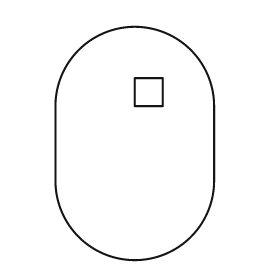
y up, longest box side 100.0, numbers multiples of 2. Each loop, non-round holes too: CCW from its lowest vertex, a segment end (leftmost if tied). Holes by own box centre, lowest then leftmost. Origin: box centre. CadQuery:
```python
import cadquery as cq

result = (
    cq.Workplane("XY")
    .moveTo(-34.0, -16.0)
    .threePointArc((0.0, -50.0), (34.0, -16.0))
    .lineTo(34.0, 16.0)
    .threePointArc((0.0, 50.0), (-34.0, 16.0))
    .close()
    .moveTo(0.0, 16.0)
    .lineTo(12.0, 16.0)
    .lineTo(12.0, 28.0)
    .lineTo(0.0, 28.0)
    .close()
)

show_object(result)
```